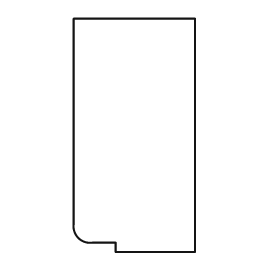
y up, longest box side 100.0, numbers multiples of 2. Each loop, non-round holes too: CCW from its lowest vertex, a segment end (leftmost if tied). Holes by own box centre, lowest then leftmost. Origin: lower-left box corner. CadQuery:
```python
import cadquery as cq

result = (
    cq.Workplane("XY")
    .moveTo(18.0, 0.0)
    .lineTo(52.0, 0.0)
    .lineTo(52.0, 100.0)
    .lineTo(0.0, 100.0)
    .lineTo(0.0, 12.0)
    .threePointArc((2.0, 6.0), (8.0, 4.0))
    .lineTo(18.0, 4.0)
    .close()
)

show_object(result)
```